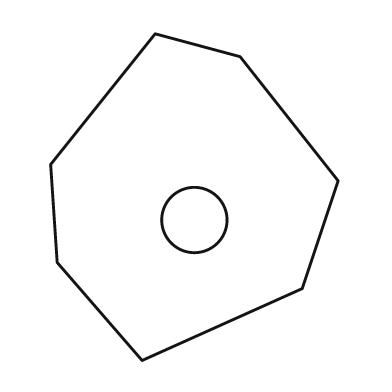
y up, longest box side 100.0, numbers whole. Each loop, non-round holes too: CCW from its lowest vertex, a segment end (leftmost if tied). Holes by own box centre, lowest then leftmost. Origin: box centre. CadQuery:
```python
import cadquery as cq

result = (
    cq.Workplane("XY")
    .moveTo(-16.0, -50.0)
    .lineTo(33.0, -28.0)
    .lineTo(44.0, 5.0)
    .lineTo(14.0, 43.0)
    .lineTo(-12.0, 50.0)
    .lineTo(-44.0, 10.0)
    .lineTo(-42.0, -20.0)
    .close()
    .moveTo(0.0, -7.0)
    .circle(10.0)
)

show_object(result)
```